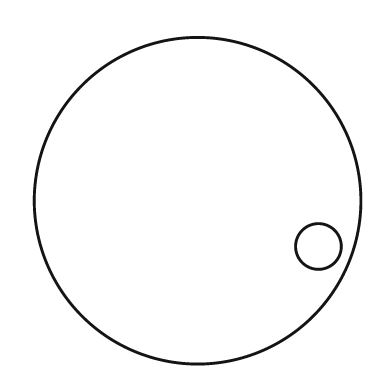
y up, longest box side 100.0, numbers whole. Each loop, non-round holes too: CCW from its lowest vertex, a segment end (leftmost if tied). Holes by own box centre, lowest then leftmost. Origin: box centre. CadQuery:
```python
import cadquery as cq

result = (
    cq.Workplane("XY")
    .moveTo(0.0, 0.0)
    .circle(50.0)
    .moveTo(37.0, -14.0)
    .circle(7.0)
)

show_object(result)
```